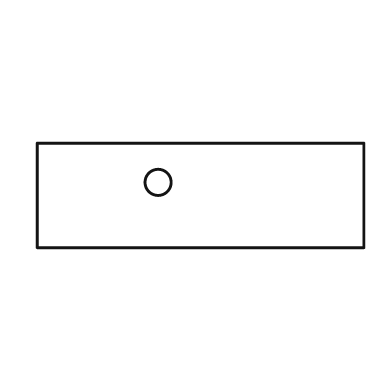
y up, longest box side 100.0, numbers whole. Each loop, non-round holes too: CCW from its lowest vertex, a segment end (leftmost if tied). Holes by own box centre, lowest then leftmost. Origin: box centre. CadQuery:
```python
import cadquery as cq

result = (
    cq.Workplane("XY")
    .moveTo(-50.0, -16.0)
    .lineTo(50.0, -16.0)
    .lineTo(50.0, 16.0)
    .lineTo(-50.0, 16.0)
    .close()
    .moveTo(-13.0, 4.0)
    .circle(4.0)
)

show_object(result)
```